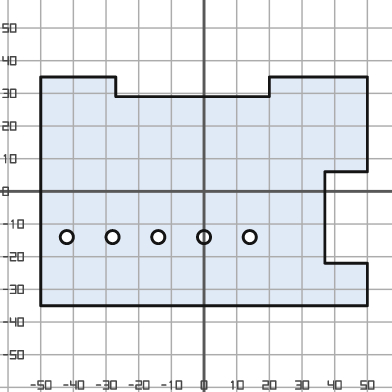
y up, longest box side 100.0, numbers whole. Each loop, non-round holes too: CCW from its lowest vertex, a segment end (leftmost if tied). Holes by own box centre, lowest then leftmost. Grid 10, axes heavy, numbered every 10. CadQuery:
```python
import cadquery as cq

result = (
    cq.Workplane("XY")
    .moveTo(-50.0, -35.0)
    .lineTo(50.0, -35.0)
    .lineTo(50.0, -22.0)
    .lineTo(37.0, -22.0)
    .lineTo(37.0, 6.0)
    .lineTo(50.0, 6.0)
    .lineTo(50.0, 35.0)
    .lineTo(20.0, 35.0)
    .lineTo(20.0, 29.0)
    .lineTo(-27.0, 29.0)
    .lineTo(-27.0, 35.0)
    .lineTo(-50.0, 35.0)
    .close()
    .moveTo(-42.0, -14.0)
    .circle(2.0)
    .moveTo(-28.0, -14.0)
    .circle(2.0)
    .moveTo(-14.0, -14.0)
    .circle(2.0)
    .moveTo(0.0, -14.0)
    .circle(2.0)
    .moveTo(14.0, -14.0)
    .circle(2.0)
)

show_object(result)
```